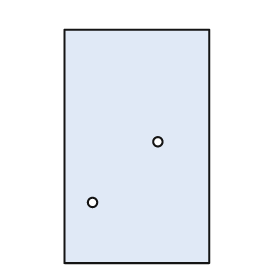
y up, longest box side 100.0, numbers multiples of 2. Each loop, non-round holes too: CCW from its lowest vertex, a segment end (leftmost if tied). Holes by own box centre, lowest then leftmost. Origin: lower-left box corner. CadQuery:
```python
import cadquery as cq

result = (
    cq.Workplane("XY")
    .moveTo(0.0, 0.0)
    .lineTo(62.0, 0.0)
    .lineTo(62.0, 100.0)
    .lineTo(0.0, 100.0)
    .close()
    .moveTo(12.0, 26.0)
    .circle(2.0)
    .moveTo(40.0, 52.0)
    .circle(2.0)
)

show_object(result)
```